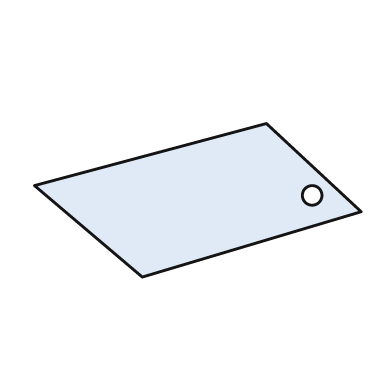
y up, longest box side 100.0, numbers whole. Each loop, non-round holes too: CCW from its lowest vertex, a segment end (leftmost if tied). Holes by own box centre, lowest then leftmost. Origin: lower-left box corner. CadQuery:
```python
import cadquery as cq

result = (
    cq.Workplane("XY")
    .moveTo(33.0, 0.0)
    .lineTo(100.0, 20.0)
    .lineTo(71.0, 47.0)
    .lineTo(0.0, 28.0)
    .close()
    .moveTo(85.0, 25.0)
    .circle(3.0)
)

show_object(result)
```